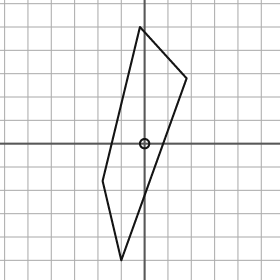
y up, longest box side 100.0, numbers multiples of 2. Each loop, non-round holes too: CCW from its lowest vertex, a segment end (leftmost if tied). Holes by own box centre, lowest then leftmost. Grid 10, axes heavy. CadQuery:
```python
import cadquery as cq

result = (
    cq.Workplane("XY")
    .moveTo(-10.0, -50.0)
    .lineTo(18.0, 28.0)
    .lineTo(-2.0, 50.0)
    .lineTo(-18.0, -16.0)
    .close()
    .moveTo(0.0, 0.0)
    .circle(2.0)
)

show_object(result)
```